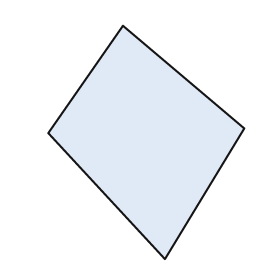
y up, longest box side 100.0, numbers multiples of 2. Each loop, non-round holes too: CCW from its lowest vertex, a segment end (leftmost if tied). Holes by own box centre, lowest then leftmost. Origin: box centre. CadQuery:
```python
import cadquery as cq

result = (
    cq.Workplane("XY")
    .moveTo(8.0, -50.0)
    .lineTo(42.0, 6.0)
    .lineTo(-10.0, 50.0)
    .lineTo(-42.0, 4.0)
    .close()
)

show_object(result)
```